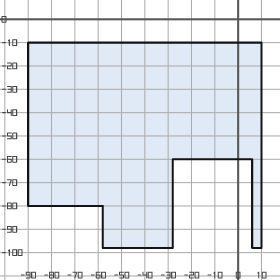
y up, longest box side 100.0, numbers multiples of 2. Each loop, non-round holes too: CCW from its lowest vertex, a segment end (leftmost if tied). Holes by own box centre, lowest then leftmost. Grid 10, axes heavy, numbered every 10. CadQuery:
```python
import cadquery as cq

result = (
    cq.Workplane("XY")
    .moveTo(-58.0, -98.0)
    .lineTo(-28.0, -98.0)
    .lineTo(-28.0, -60.0)
    .lineTo(6.0, -60.0)
    .lineTo(6.0, -98.0)
    .lineTo(10.0, -98.0)
    .lineTo(10.0, -10.0)
    .lineTo(-90.0, -10.0)
    .lineTo(-90.0, -80.0)
    .lineTo(-58.0, -80.0)
    .close()
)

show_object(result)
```